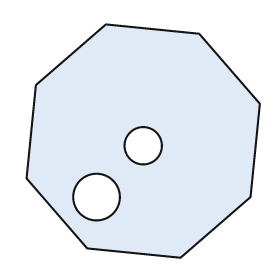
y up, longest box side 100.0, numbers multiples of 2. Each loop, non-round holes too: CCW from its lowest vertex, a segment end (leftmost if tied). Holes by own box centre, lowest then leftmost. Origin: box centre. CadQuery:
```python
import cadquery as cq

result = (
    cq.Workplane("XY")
    .moveTo(16.0, -50.0)
    .lineTo(46.0, -24.0)
    .lineTo(50.0, 16.0)
    .lineTo(24.0, 46.0)
    .lineTo(-16.0, 50.0)
    .lineTo(-46.0, 24.0)
    .lineTo(-50.0, -16.0)
    .lineTo(-24.0, -46.0)
    .close()
    .moveTo(-20.0, -24.0)
    .circle(10.0)
    .moveTo(0.0, -2.0)
    .circle(8.0)
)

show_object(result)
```